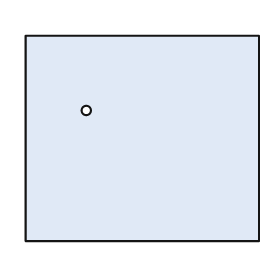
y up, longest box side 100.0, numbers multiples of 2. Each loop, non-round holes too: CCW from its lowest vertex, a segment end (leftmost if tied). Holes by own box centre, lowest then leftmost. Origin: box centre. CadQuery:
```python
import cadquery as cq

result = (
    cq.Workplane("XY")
    .moveTo(-50.0, -44.0)
    .lineTo(50.0, -44.0)
    .lineTo(50.0, 44.0)
    .lineTo(-50.0, 44.0)
    .close()
    .moveTo(-24.0, 12.0)
    .circle(2.0)
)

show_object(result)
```